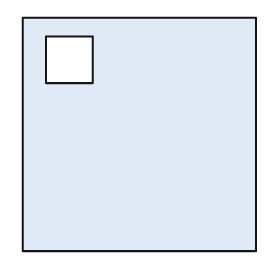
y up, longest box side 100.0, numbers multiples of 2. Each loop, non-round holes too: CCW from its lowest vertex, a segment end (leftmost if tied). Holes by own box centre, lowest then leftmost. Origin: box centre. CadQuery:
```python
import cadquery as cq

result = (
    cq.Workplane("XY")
    .moveTo(-50.0, -50.0)
    .lineTo(50.0, -50.0)
    .lineTo(50.0, 50.0)
    .lineTo(-50.0, 50.0)
    .close()
    .moveTo(-40.0, 22.0)
    .lineTo(-20.0, 22.0)
    .lineTo(-20.0, 42.0)
    .lineTo(-40.0, 42.0)
    .close()
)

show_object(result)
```